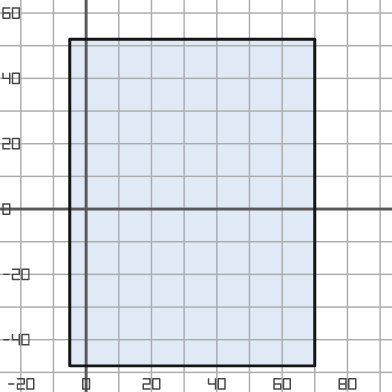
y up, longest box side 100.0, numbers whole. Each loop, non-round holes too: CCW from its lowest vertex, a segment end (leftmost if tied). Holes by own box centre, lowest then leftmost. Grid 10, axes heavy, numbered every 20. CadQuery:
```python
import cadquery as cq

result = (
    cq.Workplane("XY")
    .moveTo(-5.0, -48.0)
    .lineTo(70.0, -48.0)
    .lineTo(70.0, 52.0)
    .lineTo(-5.0, 52.0)
    .close()
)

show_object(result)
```